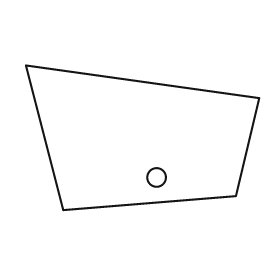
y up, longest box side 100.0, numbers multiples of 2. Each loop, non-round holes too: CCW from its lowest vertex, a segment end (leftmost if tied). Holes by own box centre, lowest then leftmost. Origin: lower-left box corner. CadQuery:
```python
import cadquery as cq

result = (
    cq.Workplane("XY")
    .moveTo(16.0, 0.0)
    .lineTo(90.0, 6.0)
    .lineTo(100.0, 48.0)
    .lineTo(0.0, 62.0)
    .close()
    .moveTo(56.0, 14.0)
    .circle(4.0)
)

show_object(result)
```